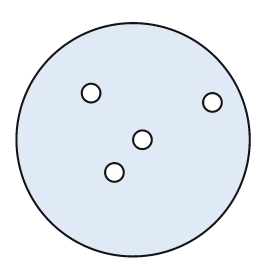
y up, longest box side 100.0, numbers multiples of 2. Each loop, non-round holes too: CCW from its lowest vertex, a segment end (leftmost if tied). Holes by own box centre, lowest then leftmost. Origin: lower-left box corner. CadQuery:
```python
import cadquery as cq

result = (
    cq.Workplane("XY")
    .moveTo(50.0, 50.0)
    .circle(50.0)
    .moveTo(42.0, 36.0)
    .circle(4.0)
    .moveTo(54.0, 50.0)
    .circle(4.0)
    .moveTo(84.0, 66.0)
    .circle(4.0)
    .moveTo(32.0, 70.0)
    .circle(4.0)
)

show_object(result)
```